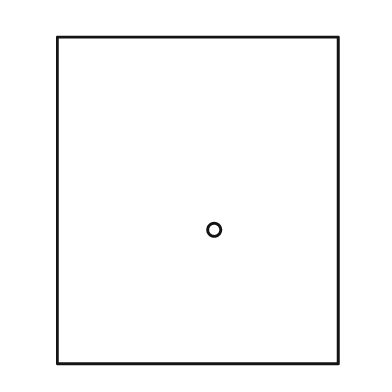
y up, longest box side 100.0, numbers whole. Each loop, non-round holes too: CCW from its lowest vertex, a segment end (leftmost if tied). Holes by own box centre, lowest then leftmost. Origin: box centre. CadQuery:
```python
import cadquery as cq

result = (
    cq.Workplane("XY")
    .moveTo(-43.0, -50.0)
    .lineTo(43.0, -50.0)
    .lineTo(43.0, 50.0)
    .lineTo(-43.0, 50.0)
    .close()
    .moveTo(5.0, -9.0)
    .circle(2.0)
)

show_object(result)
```